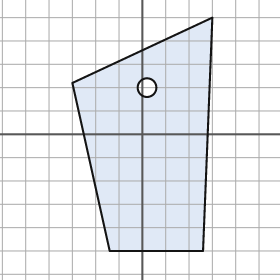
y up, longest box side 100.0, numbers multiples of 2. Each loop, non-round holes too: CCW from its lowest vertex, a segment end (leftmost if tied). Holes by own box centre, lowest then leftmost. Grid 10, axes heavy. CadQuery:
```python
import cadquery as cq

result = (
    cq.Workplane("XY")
    .moveTo(-14.0, -50.0)
    .lineTo(26.0, -50.0)
    .lineTo(30.0, 50.0)
    .lineTo(-30.0, 22.0)
    .close()
    .moveTo(2.0, 20.0)
    .circle(4.0)
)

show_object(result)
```